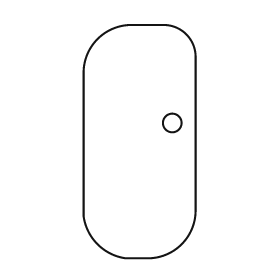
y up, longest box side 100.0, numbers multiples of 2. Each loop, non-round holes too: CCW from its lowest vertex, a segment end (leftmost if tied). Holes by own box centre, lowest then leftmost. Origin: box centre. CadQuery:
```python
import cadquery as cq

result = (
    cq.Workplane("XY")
    .moveTo(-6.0, -50.0)
    .lineTo(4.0, -50.0)
    .threePointArc((18.0, -44.0), (24.0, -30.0))
    .lineTo(24.0, 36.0)
    .threePointArc((20.0, 46.0), (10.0, 50.0))
    .lineTo(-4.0, 50.0)
    .threePointArc((-18.0, 44.0), (-24.0, 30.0))
    .lineTo(-24.0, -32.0)
    .threePointArc((-18.0, -44.0), (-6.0, -50.0))
    .close()
    .moveTo(14.0, 8.0)
    .circle(4.0)
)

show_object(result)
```